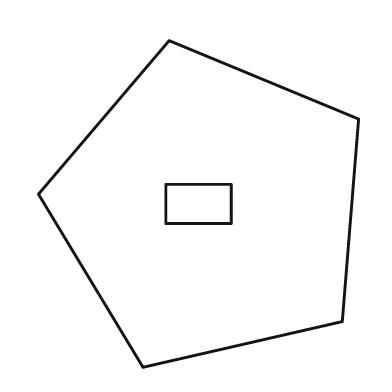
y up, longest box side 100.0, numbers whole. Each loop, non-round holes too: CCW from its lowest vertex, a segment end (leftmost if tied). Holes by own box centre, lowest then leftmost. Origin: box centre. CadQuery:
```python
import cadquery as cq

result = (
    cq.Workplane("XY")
    .moveTo(-17.0, -50.0)
    .lineTo(44.0, -36.0)
    .lineTo(49.0, 26.0)
    .lineTo(-9.0, 50.0)
    .lineTo(-49.0, 3.0)
    .close()
    .moveTo(-10.0, -6.0)
    .lineTo(10.0, -6.0)
    .lineTo(10.0, 6.0)
    .lineTo(-10.0, 6.0)
    .close()
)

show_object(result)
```